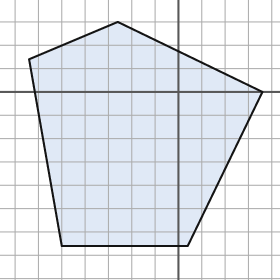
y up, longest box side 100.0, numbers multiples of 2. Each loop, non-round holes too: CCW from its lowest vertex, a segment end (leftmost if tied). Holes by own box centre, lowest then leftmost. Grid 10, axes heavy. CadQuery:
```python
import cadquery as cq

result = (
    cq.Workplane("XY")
    .moveTo(-50.0, -66.0)
    .lineTo(4.0, -66.0)
    .lineTo(36.0, 0.0)
    .lineTo(-26.0, 30.0)
    .lineTo(-64.0, 14.0)
    .close()
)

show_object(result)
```